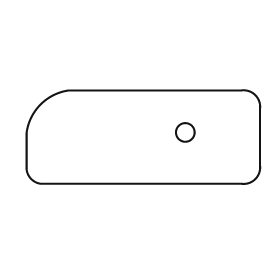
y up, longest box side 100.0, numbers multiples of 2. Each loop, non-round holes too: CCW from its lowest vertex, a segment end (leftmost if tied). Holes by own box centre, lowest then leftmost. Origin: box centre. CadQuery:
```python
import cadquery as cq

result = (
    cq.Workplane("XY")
    .moveTo(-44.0, -20.0)
    .lineTo(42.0, -20.0)
    .threePointArc((48.0, -18.0), (50.0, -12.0))
    .lineTo(50.0, 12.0)
    .threePointArc((48.0, 18.0), (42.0, 20.0))
    .lineTo(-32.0, 20.0)
    .threePointArc((-44.0, 14.0), (-50.0, 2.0))
    .lineTo(-50.0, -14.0)
    .threePointArc((-48.0, -18.0), (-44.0, -20.0))
    .close()
    .moveTo(18.0, 2.0)
    .circle(4.0)
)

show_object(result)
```